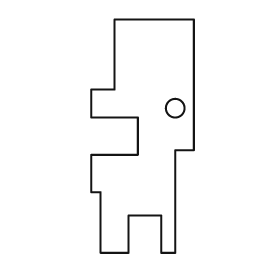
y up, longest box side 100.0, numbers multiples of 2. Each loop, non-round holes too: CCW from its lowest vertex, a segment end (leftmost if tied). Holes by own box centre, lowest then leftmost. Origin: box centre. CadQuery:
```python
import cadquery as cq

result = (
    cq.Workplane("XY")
    .moveTo(-18.0, -50.0)
    .lineTo(-6.0, -50.0)
    .lineTo(-6.0, -34.0)
    .lineTo(8.0, -34.0)
    .lineTo(8.0, -50.0)
    .lineTo(14.0, -50.0)
    .lineTo(14.0, -6.0)
    .lineTo(22.0, -6.0)
    .lineTo(22.0, 50.0)
    .lineTo(-12.0, 50.0)
    .lineTo(-12.0, 20.0)
    .lineTo(-22.0, 20.0)
    .lineTo(-22.0, 8.0)
    .lineTo(-2.0, 8.0)
    .lineTo(-2.0, -8.0)
    .lineTo(-22.0, -8.0)
    .lineTo(-22.0, -24.0)
    .lineTo(-18.0, -24.0)
    .close()
    .moveTo(14.0, 12.0)
    .circle(4.0)
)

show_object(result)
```